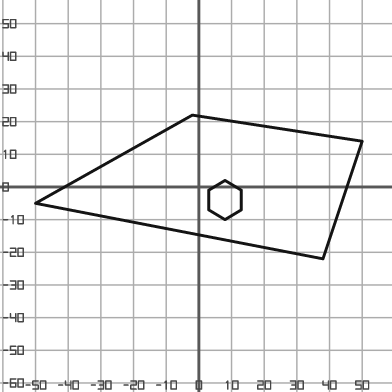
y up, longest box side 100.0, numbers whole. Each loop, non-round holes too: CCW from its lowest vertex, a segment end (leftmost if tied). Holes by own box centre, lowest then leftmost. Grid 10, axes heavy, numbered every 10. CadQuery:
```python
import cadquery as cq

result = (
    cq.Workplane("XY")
    .moveTo(38.0, -22.0)
    .lineTo(50.0, 14.0)
    .lineTo(-2.0, 22.0)
    .lineTo(-50.0, -5.0)
    .close()
    .moveTo(8.0, -10.0)
    .lineTo(13.0, -7.0)
    .lineTo(13.0, -1.0)
    .lineTo(8.0, 2.0)
    .lineTo(3.0, -1.0)
    .lineTo(3.0, -7.0)
    .close()
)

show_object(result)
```